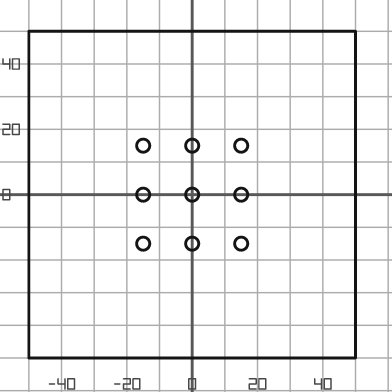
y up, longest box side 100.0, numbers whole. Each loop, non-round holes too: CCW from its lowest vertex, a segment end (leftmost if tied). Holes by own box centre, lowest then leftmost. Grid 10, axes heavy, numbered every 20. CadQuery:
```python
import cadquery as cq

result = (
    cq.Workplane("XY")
    .moveTo(-50.0, -50.0)
    .lineTo(50.0, -50.0)
    .lineTo(50.0, 50.0)
    .lineTo(-50.0, 50.0)
    .close()
    .moveTo(-15.0, -15.0)
    .circle(2.0)
    .moveTo(0.0, -15.0)
    .circle(2.0)
    .moveTo(15.0, -15.0)
    .circle(2.0)
    .moveTo(-15.0, 0.0)
    .circle(2.0)
    .moveTo(0.0, 0.0)
    .circle(2.0)
    .moveTo(15.0, 0.0)
    .circle(2.0)
    .moveTo(-15.0, 15.0)
    .circle(2.0)
    .moveTo(0.0, 15.0)
    .circle(2.0)
    .moveTo(15.0, 15.0)
    .circle(2.0)
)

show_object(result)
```